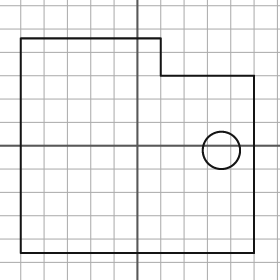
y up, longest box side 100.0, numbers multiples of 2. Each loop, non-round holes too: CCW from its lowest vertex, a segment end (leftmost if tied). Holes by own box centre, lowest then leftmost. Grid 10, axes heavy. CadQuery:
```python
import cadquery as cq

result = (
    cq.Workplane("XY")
    .moveTo(-50.0, -46.0)
    .lineTo(50.0, -46.0)
    .lineTo(50.0, 30.0)
    .lineTo(10.0, 30.0)
    .lineTo(10.0, 46.0)
    .lineTo(-50.0, 46.0)
    .close()
    .moveTo(36.0, -2.0)
    .circle(8.0)
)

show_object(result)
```